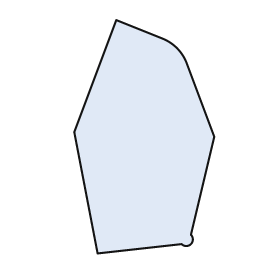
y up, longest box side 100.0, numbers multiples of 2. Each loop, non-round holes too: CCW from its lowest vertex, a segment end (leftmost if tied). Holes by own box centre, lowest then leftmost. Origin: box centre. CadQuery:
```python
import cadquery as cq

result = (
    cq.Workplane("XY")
    .moveTo(-20.0, -50.0)
    .lineTo(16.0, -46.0)
    .threePointArc((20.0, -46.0), (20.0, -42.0))
    .lineTo(30.0, 0.0)
    .lineTo(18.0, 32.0)
    .threePointArc((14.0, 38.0), (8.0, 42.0))
    .lineTo(-12.0, 50.0)
    .lineTo(-30.0, 2.0)
    .close()
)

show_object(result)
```